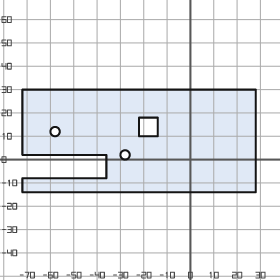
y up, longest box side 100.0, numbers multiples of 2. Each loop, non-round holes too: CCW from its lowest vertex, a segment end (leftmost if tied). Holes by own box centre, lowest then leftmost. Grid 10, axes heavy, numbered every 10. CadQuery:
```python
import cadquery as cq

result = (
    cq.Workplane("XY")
    .moveTo(-72.0, -14.0)
    .lineTo(28.0, -14.0)
    .lineTo(28.0, 30.0)
    .lineTo(-72.0, 30.0)
    .lineTo(-72.0, 2.0)
    .lineTo(-36.0, 2.0)
    .lineTo(-36.0, -8.0)
    .lineTo(-72.0, -8.0)
    .close()
    .moveTo(-28.0, 2.0)
    .circle(2.0)
    .moveTo(-58.0, 12.0)
    .circle(2.0)
    .moveTo(-22.0, 10.0)
    .lineTo(-14.0, 10.0)
    .lineTo(-14.0, 18.0)
    .lineTo(-22.0, 18.0)
    .close()
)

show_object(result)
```